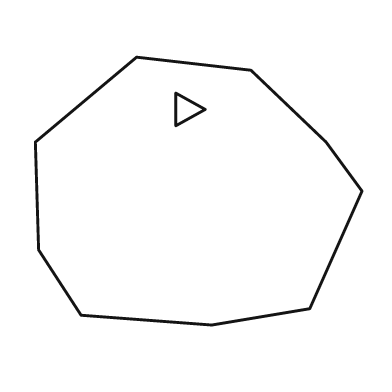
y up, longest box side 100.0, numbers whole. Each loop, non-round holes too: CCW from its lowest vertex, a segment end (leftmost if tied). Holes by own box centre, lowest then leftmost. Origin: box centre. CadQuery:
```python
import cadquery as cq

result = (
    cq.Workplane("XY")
    .moveTo(4.0, -41.0)
    .lineTo(34.0, -36.0)
    .lineTo(50.0, 0.0)
    .lineTo(39.0, 15.0)
    .lineTo(16.0, 37.0)
    .lineTo(-19.0, 41.0)
    .lineTo(-50.0, 15.0)
    .lineTo(-49.0, -18.0)
    .lineTo(-36.0, -38.0)
    .close()
    .moveTo(-7.0, 20.0)
    .lineTo(2.0, 25.0)
    .lineTo(-7.0, 30.0)
    .close()
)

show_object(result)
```